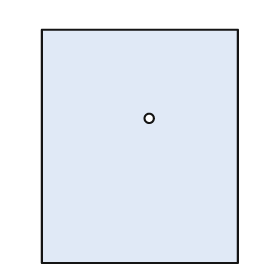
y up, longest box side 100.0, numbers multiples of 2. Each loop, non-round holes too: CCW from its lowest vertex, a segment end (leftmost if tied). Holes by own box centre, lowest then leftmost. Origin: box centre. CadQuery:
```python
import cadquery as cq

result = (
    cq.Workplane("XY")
    .moveTo(-42.0, -50.0)
    .lineTo(42.0, -50.0)
    .lineTo(42.0, 50.0)
    .lineTo(-42.0, 50.0)
    .close()
    .moveTo(4.0, 12.0)
    .circle(2.0)
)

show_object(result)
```